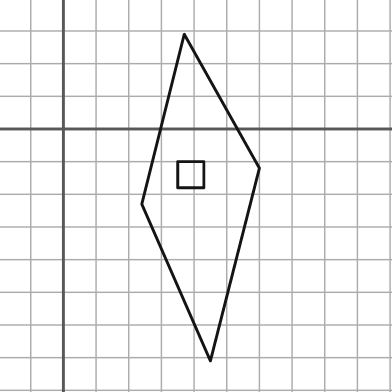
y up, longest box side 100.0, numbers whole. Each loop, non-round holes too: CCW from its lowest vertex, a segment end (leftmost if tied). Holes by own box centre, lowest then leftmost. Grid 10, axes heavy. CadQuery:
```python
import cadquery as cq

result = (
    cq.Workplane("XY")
    .moveTo(45.0, -71.0)
    .lineTo(60.0, -12.0)
    .lineTo(37.0, 29.0)
    .lineTo(24.0, -23.0)
    .close()
    .moveTo(35.0, -18.0)
    .lineTo(43.0, -18.0)
    .lineTo(43.0, -10.0)
    .lineTo(35.0, -10.0)
    .close()
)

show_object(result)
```